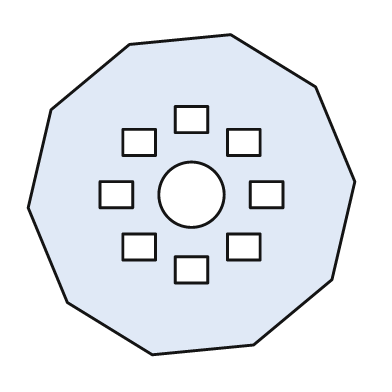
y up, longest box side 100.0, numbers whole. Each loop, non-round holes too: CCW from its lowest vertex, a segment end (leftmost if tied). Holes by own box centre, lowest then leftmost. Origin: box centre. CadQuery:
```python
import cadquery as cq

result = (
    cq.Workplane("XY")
    .moveTo(-12.0, -49.0)
    .lineTo(19.0, -46.0)
    .lineTo(43.0, -26.0)
    .lineTo(50.0, 4.0)
    .lineTo(38.0, 33.0)
    .lineTo(12.0, 49.0)
    .lineTo(-19.0, 46.0)
    .lineTo(-43.0, 26.0)
    .lineTo(-50.0, -4.0)
    .lineTo(-38.0, -33.0)
    .close()
    .moveTo(-5.0, -27.0)
    .lineTo(5.0, -27.0)
    .lineTo(5.0, -19.0)
    .lineTo(-5.0, -19.0)
    .close()
    .moveTo(-21.0, -20.0)
    .lineTo(-11.0, -20.0)
    .lineTo(-11.0, -12.0)
    .lineTo(-21.0, -12.0)
    .close()
    .moveTo(11.0, -20.0)
    .lineTo(21.0, -20.0)
    .lineTo(21.0, -12.0)
    .lineTo(11.0, -12.0)
    .close()
    .moveTo(-28.0, -4.0)
    .lineTo(-18.0, -4.0)
    .lineTo(-18.0, 4.0)
    .lineTo(-28.0, 4.0)
    .close()
    .moveTo(0.0, 0.0)
    .circle(10.0)
    .moveTo(18.0, -4.0)
    .lineTo(28.0, -4.0)
    .lineTo(28.0, 4.0)
    .lineTo(18.0, 4.0)
    .close()
    .moveTo(-21.0, 12.0)
    .lineTo(-11.0, 12.0)
    .lineTo(-11.0, 20.0)
    .lineTo(-21.0, 20.0)
    .close()
    .moveTo(11.0, 12.0)
    .lineTo(21.0, 12.0)
    .lineTo(21.0, 20.0)
    .lineTo(11.0, 20.0)
    .close()
    .moveTo(-5.0, 19.0)
    .lineTo(5.0, 19.0)
    .lineTo(5.0, 27.0)
    .lineTo(-5.0, 27.0)
    .close()
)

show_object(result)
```